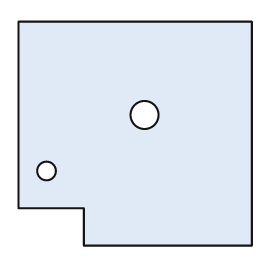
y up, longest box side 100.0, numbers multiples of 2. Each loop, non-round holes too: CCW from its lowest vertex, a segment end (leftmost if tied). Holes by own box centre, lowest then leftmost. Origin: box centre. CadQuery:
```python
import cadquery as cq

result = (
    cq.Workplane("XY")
    .moveTo(-22.0, -48.0)
    .lineTo(50.0, -48.0)
    .lineTo(50.0, 48.0)
    .lineTo(-50.0, 48.0)
    .lineTo(-50.0, -32.0)
    .lineTo(-22.0, -32.0)
    .close()
    .moveTo(-38.0, -16.0)
    .circle(4.0)
    .moveTo(4.0, 8.0)
    .circle(6.0)
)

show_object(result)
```